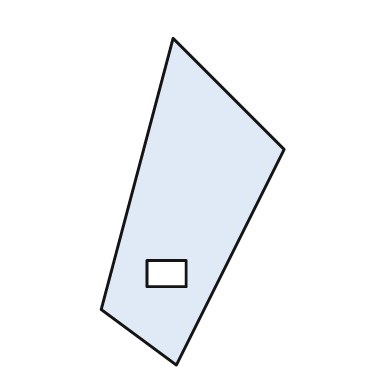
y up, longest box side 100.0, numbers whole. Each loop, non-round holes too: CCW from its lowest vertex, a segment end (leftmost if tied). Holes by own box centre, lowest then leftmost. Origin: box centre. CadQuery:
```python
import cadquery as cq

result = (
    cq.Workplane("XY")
    .moveTo(-5.0, -50.0)
    .lineTo(28.0, 16.0)
    .lineTo(-6.0, 50.0)
    .lineTo(-28.0, -33.0)
    .close()
    .moveTo(-14.0, -26.0)
    .lineTo(-2.0, -26.0)
    .lineTo(-2.0, -18.0)
    .lineTo(-14.0, -18.0)
    .close()
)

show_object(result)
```